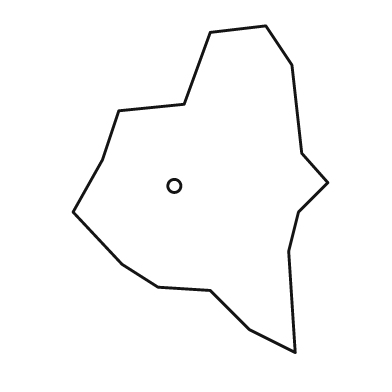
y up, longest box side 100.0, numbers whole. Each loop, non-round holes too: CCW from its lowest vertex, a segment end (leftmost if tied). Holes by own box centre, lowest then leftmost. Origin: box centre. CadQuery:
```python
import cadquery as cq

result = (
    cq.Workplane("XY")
    .moveTo(29.0, -50.0)
    .lineTo(27.0, -19.0)
    .lineTo(30.0, -7.0)
    .lineTo(39.0, 2.0)
    .lineTo(31.0, 11.0)
    .lineTo(28.0, 38.0)
    .lineTo(20.0, 50.0)
    .lineTo(3.0, 48.0)
    .lineTo(-5.0, 26.0)
    .lineTo(-25.0, 24.0)
    .lineTo(-30.0, 9.0)
    .lineTo(-39.0, -7.0)
    .lineTo(-24.0, -23.0)
    .lineTo(-13.0, -30.0)
    .lineTo(3.0, -31.0)
    .lineTo(15.0, -43.0)
    .close()
    .moveTo(-8.0, 1.0)
    .circle(2.0)
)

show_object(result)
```